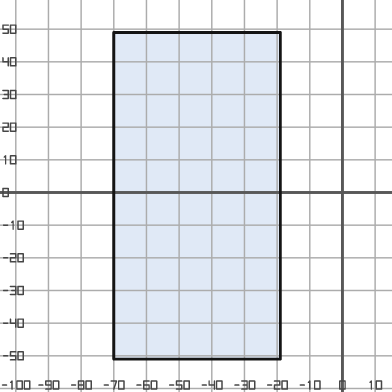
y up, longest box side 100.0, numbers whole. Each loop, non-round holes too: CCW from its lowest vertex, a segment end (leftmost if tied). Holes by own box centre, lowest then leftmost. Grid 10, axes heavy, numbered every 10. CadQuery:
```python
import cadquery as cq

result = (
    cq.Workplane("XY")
    .moveTo(-70.0, -51.0)
    .lineTo(-19.0, -51.0)
    .lineTo(-19.0, 49.0)
    .lineTo(-70.0, 49.0)
    .close()
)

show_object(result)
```